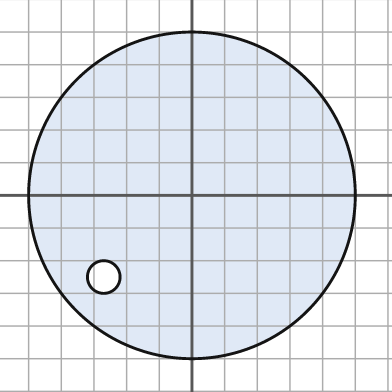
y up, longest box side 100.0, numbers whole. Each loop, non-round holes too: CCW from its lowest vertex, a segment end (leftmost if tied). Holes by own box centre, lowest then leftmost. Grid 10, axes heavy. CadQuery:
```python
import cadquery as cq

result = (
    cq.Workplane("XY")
    .moveTo(0.0, 0.0)
    .circle(50.0)
    .moveTo(-27.0, -25.0)
    .circle(5.0)
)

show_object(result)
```